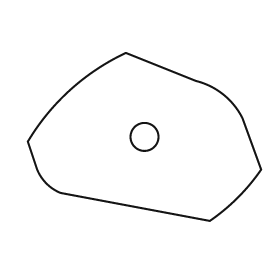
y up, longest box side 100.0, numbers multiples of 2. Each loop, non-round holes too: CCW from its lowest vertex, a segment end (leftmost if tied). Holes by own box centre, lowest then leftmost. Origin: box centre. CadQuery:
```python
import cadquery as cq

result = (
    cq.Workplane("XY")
    .moveTo(28.0, -36.0)
    .threePointArc((40.0, -26.0), (50.0, -14.0))
    .lineTo(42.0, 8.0)
    .threePointArc((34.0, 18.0), (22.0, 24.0))
    .lineTo(-8.0, 36.0)
    .threePointArc((-32.0, 20.0), (-50.0, -2.0))
    .lineTo(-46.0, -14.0)
    .threePointArc((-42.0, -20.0), (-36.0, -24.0))
    .close()
    .moveTo(0.0, 0.0)
    .circle(6.0)
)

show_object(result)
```